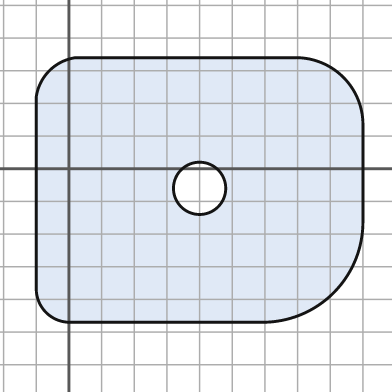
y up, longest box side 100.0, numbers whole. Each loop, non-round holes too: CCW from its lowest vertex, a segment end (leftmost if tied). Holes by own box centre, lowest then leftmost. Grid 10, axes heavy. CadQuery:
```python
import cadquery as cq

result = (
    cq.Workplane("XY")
    .moveTo(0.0, -47.0)
    .lineTo(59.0, -47.0)
    .threePointArc((81.0, -38.0), (90.0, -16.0))
    .lineTo(90.0, 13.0)
    .threePointArc((84.0, 28.0), (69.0, 34.0))
    .lineTo(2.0, 34.0)
    .threePointArc((-6.0, 30.0), (-10.0, 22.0))
    .lineTo(-10.0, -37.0)
    .threePointArc((-7.0, -44.0), (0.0, -47.0))
    .close()
    .moveTo(40.0, -6.0)
    .circle(8.0)
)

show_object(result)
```